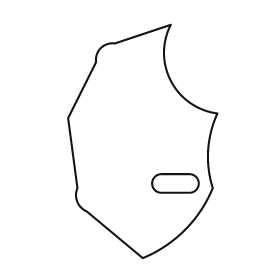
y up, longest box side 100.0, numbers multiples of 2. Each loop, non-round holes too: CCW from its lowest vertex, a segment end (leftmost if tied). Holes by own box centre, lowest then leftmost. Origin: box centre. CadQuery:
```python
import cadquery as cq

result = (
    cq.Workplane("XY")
    .moveTo(0.0, -50.0)
    .threePointArc((18.0, -38.0), (30.0, -20.0))
    .threePointArc((28.0, -4.0), (32.0, 12.0))
    .threePointArc((12.0, 26.0), (12.0, 50.0))
    .lineTo(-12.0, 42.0)
    .threePointArc((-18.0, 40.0), (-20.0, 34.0))
    .lineTo(-32.0, 10.0)
    .lineTo(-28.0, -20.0)
    .threePointArc((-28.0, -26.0), (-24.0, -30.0))
    .close()
    .moveTo(8.0, -22.0)
    .lineTo(20.0, -22.0)
    .threePointArc((24.0, -18.0), (20.0, -14.0))
    .lineTo(8.0, -14.0)
    .threePointArc((4.0, -18.0), (8.0, -22.0))
    .close()
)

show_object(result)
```